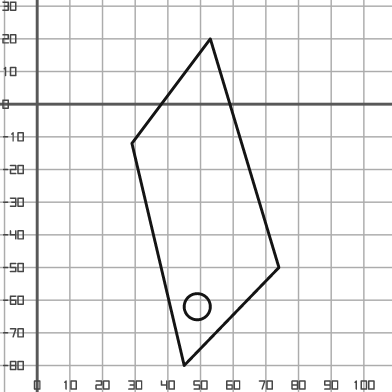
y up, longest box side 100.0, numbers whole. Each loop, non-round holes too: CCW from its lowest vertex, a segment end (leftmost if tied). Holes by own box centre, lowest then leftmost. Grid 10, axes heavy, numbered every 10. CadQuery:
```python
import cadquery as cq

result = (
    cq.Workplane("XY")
    .moveTo(45.0, -80.0)
    .lineTo(74.0, -50.0)
    .lineTo(53.0, 20.0)
    .lineTo(29.0, -12.0)
    .close()
    .moveTo(49.0, -62.0)
    .circle(4.0)
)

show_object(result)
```